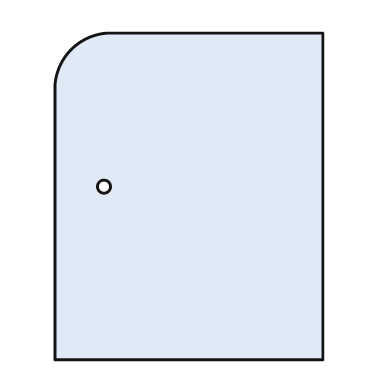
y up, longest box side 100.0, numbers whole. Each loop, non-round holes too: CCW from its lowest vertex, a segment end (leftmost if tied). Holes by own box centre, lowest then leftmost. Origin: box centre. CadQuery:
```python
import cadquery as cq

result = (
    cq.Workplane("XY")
    .moveTo(-41.0, -50.0)
    .lineTo(41.0, -50.0)
    .lineTo(41.0, 50.0)
    .lineTo(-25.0, 50.0)
    .threePointArc((-36.0, 45.0), (-41.0, 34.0))
    .close()
    .moveTo(-26.0, 3.0)
    .circle(2.0)
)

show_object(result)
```